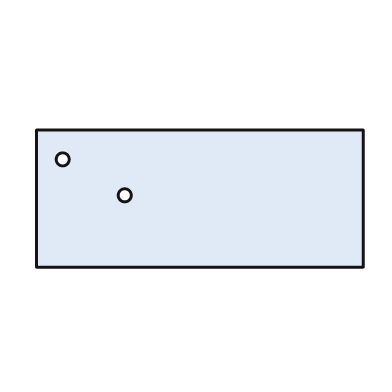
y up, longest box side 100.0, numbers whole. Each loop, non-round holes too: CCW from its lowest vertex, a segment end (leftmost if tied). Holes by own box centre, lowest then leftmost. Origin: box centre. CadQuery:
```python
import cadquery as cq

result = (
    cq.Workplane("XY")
    .moveTo(-50.0, -21.0)
    .lineTo(50.0, -21.0)
    .lineTo(50.0, 21.0)
    .lineTo(-50.0, 21.0)
    .close()
    .moveTo(-23.0, 1.0)
    .circle(2.0)
    .moveTo(-42.0, 12.0)
    .circle(2.0)
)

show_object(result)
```